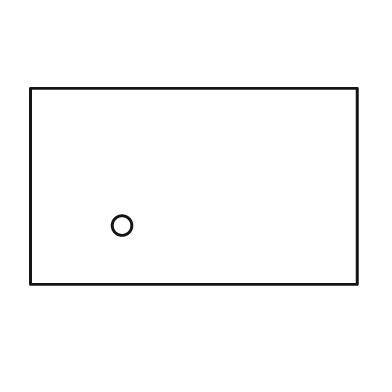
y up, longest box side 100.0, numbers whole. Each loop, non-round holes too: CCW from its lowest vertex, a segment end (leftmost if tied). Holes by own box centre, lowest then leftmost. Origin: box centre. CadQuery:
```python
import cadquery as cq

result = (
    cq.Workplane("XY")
    .moveTo(-50.0, -30.0)
    .lineTo(50.0, -30.0)
    .lineTo(50.0, 30.0)
    .lineTo(-50.0, 30.0)
    .close()
    .moveTo(-22.0, -12.0)
    .circle(3.0)
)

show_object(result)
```